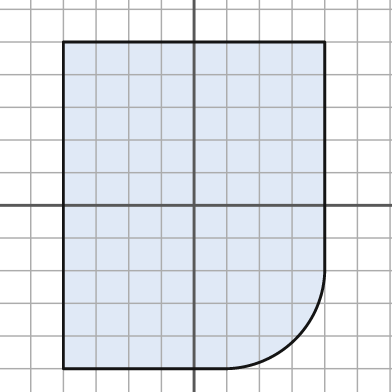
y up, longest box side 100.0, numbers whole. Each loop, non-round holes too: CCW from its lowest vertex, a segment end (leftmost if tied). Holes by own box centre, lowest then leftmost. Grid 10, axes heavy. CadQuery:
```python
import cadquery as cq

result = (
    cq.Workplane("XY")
    .moveTo(-40.0, -50.0)
    .lineTo(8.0, -50.0)
    .threePointArc((31.0, -41.0), (40.0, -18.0))
    .lineTo(40.0, 50.0)
    .lineTo(-40.0, 50.0)
    .close()
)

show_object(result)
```